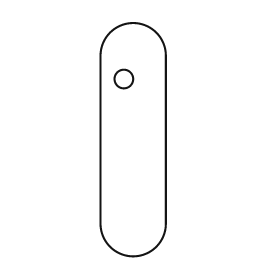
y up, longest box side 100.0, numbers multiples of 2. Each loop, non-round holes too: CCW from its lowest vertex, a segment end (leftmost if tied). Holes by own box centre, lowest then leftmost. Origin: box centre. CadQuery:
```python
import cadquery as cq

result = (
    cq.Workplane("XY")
    .moveTo(-14.0, -36.0)
    .threePointArc((0.0, -50.0), (14.0, -36.0))
    .lineTo(14.0, 36.0)
    .threePointArc((0.0, 50.0), (-14.0, 36.0))
    .close()
    .moveTo(-4.0, 26.0)
    .circle(4.0)
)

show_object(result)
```